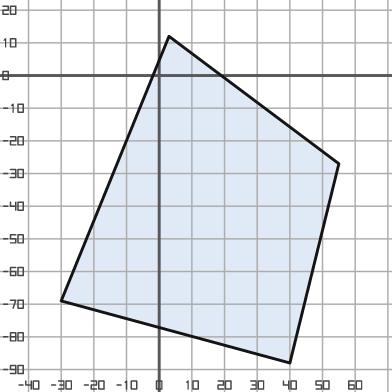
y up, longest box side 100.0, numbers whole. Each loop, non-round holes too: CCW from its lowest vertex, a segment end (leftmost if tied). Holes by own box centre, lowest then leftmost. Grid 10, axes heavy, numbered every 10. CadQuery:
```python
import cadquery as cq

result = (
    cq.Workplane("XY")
    .moveTo(40.0, -88.0)
    .lineTo(55.0, -27.0)
    .lineTo(3.0, 12.0)
    .lineTo(-30.0, -69.0)
    .close()
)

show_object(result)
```